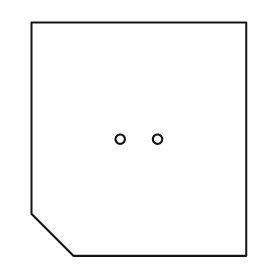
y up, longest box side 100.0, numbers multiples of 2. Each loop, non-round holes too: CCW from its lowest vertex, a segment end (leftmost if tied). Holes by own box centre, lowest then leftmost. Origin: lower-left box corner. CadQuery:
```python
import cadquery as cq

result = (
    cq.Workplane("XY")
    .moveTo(18.0, 0.0)
    .lineTo(92.0, 0.0)
    .lineTo(92.0, 100.0)
    .lineTo(0.0, 100.0)
    .lineTo(0.0, 18.0)
    .close()
    .moveTo(38.0, 50.0)
    .circle(2.0)
    .moveTo(54.0, 50.0)
    .circle(2.0)
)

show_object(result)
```